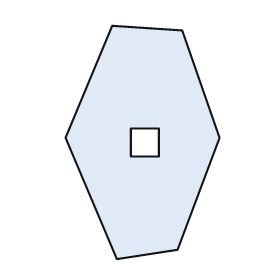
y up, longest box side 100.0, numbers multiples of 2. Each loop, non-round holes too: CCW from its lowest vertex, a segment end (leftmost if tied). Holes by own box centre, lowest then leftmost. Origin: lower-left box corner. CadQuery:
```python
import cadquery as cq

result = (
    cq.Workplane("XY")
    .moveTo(22.0, 0.0)
    .lineTo(48.0, 4.0)
    .lineTo(66.0, 52.0)
    .lineTo(50.0, 98.0)
    .lineTo(20.0, 100.0)
    .lineTo(0.0, 52.0)
    .close()
    .moveTo(28.0, 44.0)
    .lineTo(40.0, 44.0)
    .lineTo(40.0, 56.0)
    .lineTo(28.0, 56.0)
    .close()
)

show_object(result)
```